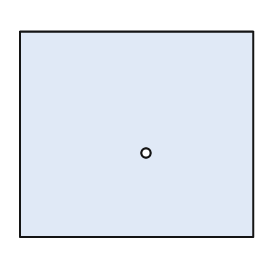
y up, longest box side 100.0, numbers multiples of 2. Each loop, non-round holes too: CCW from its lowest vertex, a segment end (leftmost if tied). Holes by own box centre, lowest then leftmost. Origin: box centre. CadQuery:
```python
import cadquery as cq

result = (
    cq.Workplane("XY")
    .moveTo(-50.0, -44.0)
    .lineTo(50.0, -44.0)
    .lineTo(50.0, 44.0)
    .lineTo(-50.0, 44.0)
    .close()
    .moveTo(4.0, -8.0)
    .circle(2.0)
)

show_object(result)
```